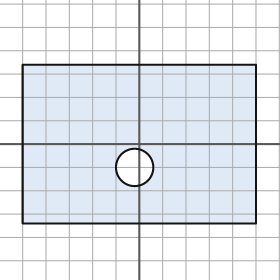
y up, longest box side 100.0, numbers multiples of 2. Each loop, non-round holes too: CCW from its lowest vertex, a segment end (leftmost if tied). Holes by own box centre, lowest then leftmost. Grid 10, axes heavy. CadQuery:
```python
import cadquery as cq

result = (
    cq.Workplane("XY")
    .moveTo(-50.0, -34.0)
    .lineTo(50.0, -34.0)
    .lineTo(50.0, 34.0)
    .lineTo(-50.0, 34.0)
    .close()
    .moveTo(-2.0, -10.0)
    .circle(8.0)
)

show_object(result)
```